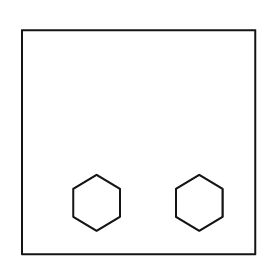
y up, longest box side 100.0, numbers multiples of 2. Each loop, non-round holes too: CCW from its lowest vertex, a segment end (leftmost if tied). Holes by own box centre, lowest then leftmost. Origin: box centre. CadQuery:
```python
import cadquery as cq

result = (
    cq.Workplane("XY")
    .moveTo(-50.0, -48.0)
    .lineTo(50.0, -48.0)
    .lineTo(50.0, 48.0)
    .lineTo(-50.0, 48.0)
    .close()
    .moveTo(-18.0, -38.0)
    .lineTo(-8.0, -32.0)
    .lineTo(-8.0, -20.0)
    .lineTo(-18.0, -14.0)
    .lineTo(-28.0, -20.0)
    .lineTo(-28.0, -32.0)
    .close()
    .moveTo(26.0, -38.0)
    .lineTo(36.0, -32.0)
    .lineTo(36.0, -20.0)
    .lineTo(26.0, -14.0)
    .lineTo(16.0, -20.0)
    .lineTo(16.0, -32.0)
    .close()
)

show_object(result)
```